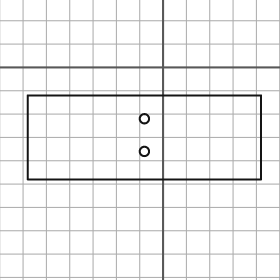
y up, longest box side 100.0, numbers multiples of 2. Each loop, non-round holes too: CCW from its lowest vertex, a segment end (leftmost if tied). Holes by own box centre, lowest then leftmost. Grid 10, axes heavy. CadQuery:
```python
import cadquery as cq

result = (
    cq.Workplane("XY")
    .moveTo(-58.0, -48.0)
    .lineTo(42.0, -48.0)
    .lineTo(42.0, -12.0)
    .lineTo(-58.0, -12.0)
    .close()
    .moveTo(-8.0, -36.0)
    .circle(2.0)
    .moveTo(-8.0, -22.0)
    .circle(2.0)
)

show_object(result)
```